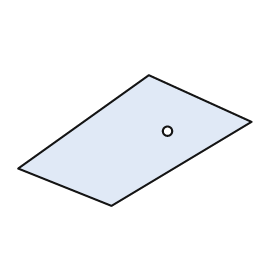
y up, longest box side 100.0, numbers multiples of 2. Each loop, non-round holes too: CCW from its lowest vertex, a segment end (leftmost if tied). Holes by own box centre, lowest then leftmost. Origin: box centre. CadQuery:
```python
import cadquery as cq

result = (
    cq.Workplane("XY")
    .moveTo(-10.0, -28.0)
    .lineTo(50.0, 8.0)
    .lineTo(6.0, 28.0)
    .lineTo(-50.0, -12.0)
    .close()
    .moveTo(14.0, 4.0)
    .circle(2.0)
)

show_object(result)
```